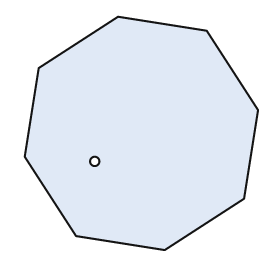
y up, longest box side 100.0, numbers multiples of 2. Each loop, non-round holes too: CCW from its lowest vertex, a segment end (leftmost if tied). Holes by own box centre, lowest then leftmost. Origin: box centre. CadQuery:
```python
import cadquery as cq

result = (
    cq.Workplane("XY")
    .moveTo(10.0, -50.0)
    .lineTo(44.0, -28.0)
    .lineTo(50.0, 10.0)
    .lineTo(28.0, 44.0)
    .lineTo(-10.0, 50.0)
    .lineTo(-44.0, 28.0)
    .lineTo(-50.0, -10.0)
    .lineTo(-28.0, -44.0)
    .close()
    .moveTo(-20.0, -12.0)
    .circle(2.0)
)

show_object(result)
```